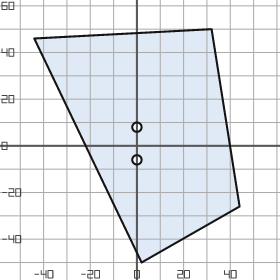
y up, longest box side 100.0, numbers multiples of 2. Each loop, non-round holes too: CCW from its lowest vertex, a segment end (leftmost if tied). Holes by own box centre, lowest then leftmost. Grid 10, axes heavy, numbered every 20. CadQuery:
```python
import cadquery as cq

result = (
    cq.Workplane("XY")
    .moveTo(2.0, -50.0)
    .lineTo(44.0, -26.0)
    .lineTo(32.0, 50.0)
    .lineTo(-44.0, 46.0)
    .close()
    .moveTo(0.0, -6.0)
    .circle(2.0)
    .moveTo(0.0, 8.0)
    .circle(2.0)
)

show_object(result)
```